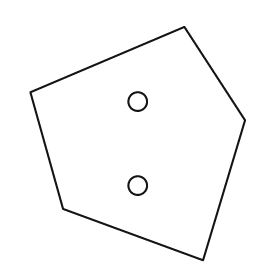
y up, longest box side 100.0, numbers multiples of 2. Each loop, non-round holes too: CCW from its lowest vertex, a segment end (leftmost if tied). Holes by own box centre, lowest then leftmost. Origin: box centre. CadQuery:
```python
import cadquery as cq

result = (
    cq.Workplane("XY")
    .moveTo(28.0, -50.0)
    .lineTo(46.0, 10.0)
    .lineTo(20.0, 50.0)
    .lineTo(-46.0, 22.0)
    .lineTo(-32.0, -28.0)
    .close()
    .moveTo(0.0, -18.0)
    .circle(4.0)
    .moveTo(0.0, 18.0)
    .circle(4.0)
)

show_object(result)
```